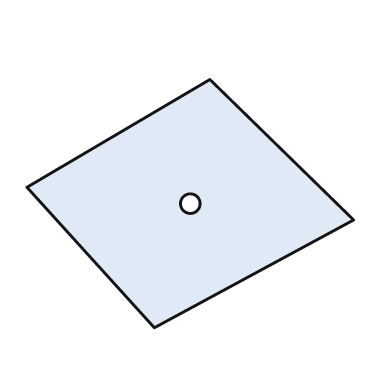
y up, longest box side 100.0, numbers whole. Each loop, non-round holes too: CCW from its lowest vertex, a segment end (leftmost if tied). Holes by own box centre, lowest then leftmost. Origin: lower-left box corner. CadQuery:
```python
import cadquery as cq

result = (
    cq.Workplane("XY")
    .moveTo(39.0, 0.0)
    .lineTo(100.0, 33.0)
    .lineTo(56.0, 76.0)
    .lineTo(0.0, 43.0)
    .close()
    .moveTo(50.0, 38.0)
    .circle(3.0)
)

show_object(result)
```